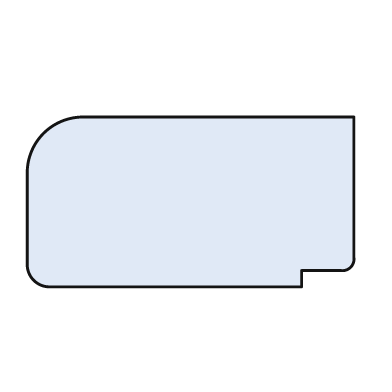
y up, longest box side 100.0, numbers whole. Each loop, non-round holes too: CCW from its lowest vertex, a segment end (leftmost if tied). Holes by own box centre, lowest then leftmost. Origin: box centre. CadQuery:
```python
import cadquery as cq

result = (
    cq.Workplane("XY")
    .moveTo(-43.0, -26.0)
    .lineTo(34.0, -26.0)
    .lineTo(34.0, -21.0)
    .lineTo(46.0, -21.0)
    .threePointArc((49.0, -20.0), (50.0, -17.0))
    .lineTo(50.0, 26.0)
    .lineTo(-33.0, 26.0)
    .threePointArc((-45.0, 21.0), (-50.0, 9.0))
    .lineTo(-50.0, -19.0)
    .threePointArc((-48.0, -24.0), (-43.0, -26.0))
    .close()
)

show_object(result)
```